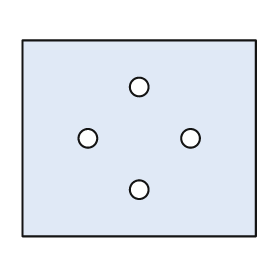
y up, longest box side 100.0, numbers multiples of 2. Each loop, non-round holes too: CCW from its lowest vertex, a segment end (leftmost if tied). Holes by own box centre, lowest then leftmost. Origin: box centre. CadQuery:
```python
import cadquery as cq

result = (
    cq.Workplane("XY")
    .moveTo(-50.0, -42.0)
    .lineTo(50.0, -42.0)
    .lineTo(50.0, 42.0)
    .lineTo(-50.0, 42.0)
    .close()
    .moveTo(0.0, -22.0)
    .circle(4.0)
    .moveTo(-22.0, 0.0)
    .circle(4.0)
    .moveTo(22.0, 0.0)
    .circle(4.0)
    .moveTo(0.0, 22.0)
    .circle(4.0)
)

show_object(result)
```